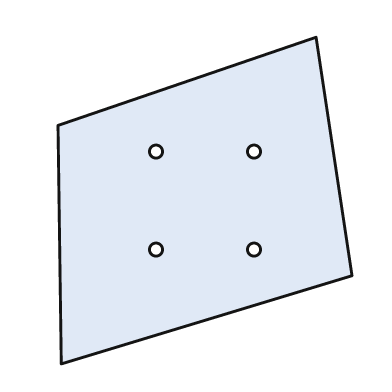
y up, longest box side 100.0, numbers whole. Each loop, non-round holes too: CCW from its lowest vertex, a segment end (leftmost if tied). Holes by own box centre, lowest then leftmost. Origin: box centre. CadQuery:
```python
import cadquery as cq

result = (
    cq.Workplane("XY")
    .moveTo(-44.0, -50.0)
    .lineTo(45.0, -23.0)
    .lineTo(34.0, 50.0)
    .lineTo(-45.0, 23.0)
    .close()
    .moveTo(-15.0, -15.0)
    .circle(2.0)
    .moveTo(15.0, -15.0)
    .circle(2.0)
    .moveTo(-15.0, 15.0)
    .circle(2.0)
    .moveTo(15.0, 15.0)
    .circle(2.0)
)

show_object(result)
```